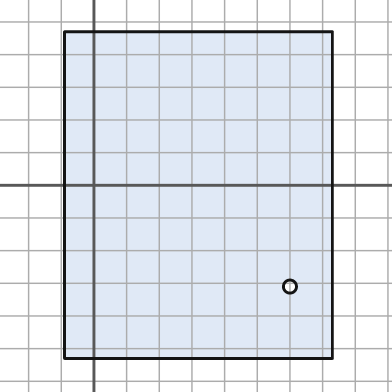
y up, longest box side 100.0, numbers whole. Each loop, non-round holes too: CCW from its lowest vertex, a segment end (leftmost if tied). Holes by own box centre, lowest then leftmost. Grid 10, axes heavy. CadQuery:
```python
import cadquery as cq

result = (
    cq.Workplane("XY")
    .moveTo(-9.0, -53.0)
    .lineTo(73.0, -53.0)
    .lineTo(73.0, 47.0)
    .lineTo(-9.0, 47.0)
    .close()
    .moveTo(60.0, -31.0)
    .circle(2.0)
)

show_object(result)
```